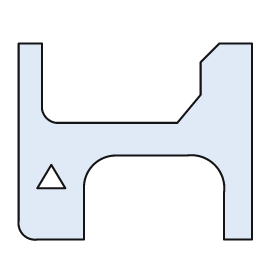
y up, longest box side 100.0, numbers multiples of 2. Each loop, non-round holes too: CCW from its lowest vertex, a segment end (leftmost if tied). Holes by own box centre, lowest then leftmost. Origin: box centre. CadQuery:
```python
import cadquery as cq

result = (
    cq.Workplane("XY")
    .moveTo(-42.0, -42.0)
    .lineTo(-22.0, -42.0)
    .lineTo(-22.0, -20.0)
    .threePointArc((-18.0, -10.0), (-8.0, -6.0))
    .lineTo(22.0, -6.0)
    .threePointArc((34.0, -10.0), (38.0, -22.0))
    .lineTo(38.0, -42.0)
    .lineTo(50.0, -42.0)
    .lineTo(50.0, 42.0)
    .lineTo(36.0, 42.0)
    .lineTo(28.0, 34.0)
    .lineTo(28.0, 20.0)
    .lineTo(18.0, 8.0)
    .lineTo(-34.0, 8.0)
    .threePointArc((-38.0, 10.0), (-40.0, 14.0))
    .lineTo(-40.0, 42.0)
    .lineTo(-50.0, 42.0)
    .lineTo(-50.0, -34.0)
    .threePointArc((-48.0, -40.0), (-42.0, -42.0))
    .close()
    .moveTo(-42.0, -20.0)
    .lineTo(-30.0, -20.0)
    .lineTo(-36.0, -10.0)
    .close()
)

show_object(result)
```